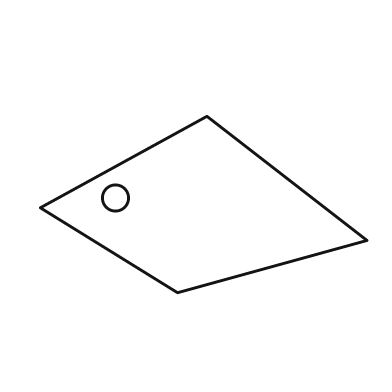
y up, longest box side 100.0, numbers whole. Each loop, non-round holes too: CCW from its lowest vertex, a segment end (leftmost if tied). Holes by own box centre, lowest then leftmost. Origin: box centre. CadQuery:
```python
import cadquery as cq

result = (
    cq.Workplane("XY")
    .moveTo(-8.0, -27.0)
    .lineTo(50.0, -11.0)
    .lineTo(1.0, 27.0)
    .lineTo(-50.0, -1.0)
    .close()
    .moveTo(-27.0, 2.0)
    .circle(4.0)
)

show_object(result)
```